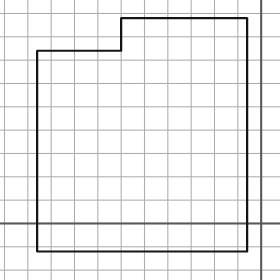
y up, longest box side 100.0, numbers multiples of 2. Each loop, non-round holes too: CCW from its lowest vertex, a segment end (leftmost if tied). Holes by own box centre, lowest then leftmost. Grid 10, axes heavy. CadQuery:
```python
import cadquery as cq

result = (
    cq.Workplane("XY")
    .moveTo(-96.0, -12.0)
    .lineTo(-6.0, -12.0)
    .lineTo(-6.0, 88.0)
    .lineTo(-60.0, 88.0)
    .lineTo(-60.0, 74.0)
    .lineTo(-96.0, 74.0)
    .close()
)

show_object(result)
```